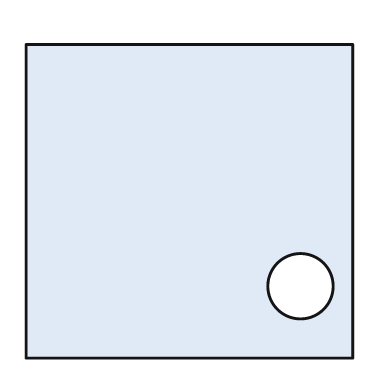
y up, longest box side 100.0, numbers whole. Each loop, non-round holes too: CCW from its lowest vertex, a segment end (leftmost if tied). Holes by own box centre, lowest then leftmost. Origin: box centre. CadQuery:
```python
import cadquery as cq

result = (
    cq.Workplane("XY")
    .moveTo(-50.0, -48.0)
    .lineTo(50.0, -48.0)
    .lineTo(50.0, 48.0)
    .lineTo(-50.0, 48.0)
    .close()
    .moveTo(34.0, -26.0)
    .circle(10.0)
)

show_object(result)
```